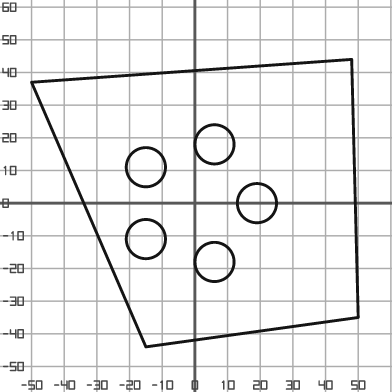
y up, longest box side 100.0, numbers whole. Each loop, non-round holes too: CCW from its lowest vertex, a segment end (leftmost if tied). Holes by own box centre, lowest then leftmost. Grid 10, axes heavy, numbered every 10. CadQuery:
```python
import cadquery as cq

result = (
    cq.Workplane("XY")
    .moveTo(-15.0, -44.0)
    .lineTo(50.0, -35.0)
    .lineTo(48.0, 44.0)
    .lineTo(-50.0, 37.0)
    .close()
    .moveTo(6.0, -18.0)
    .circle(6.0)
    .moveTo(-15.0, -11.0)
    .circle(6.0)
    .moveTo(19.0, 0.0)
    .circle(6.0)
    .moveTo(-15.0, 11.0)
    .circle(6.0)
    .moveTo(6.0, 18.0)
    .circle(6.0)
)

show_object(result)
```